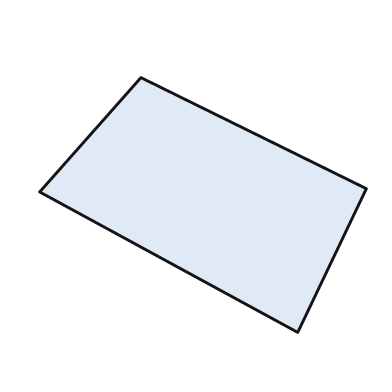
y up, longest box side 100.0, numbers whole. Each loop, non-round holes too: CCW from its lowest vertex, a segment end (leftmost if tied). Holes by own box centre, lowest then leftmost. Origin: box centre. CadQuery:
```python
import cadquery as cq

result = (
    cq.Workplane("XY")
    .moveTo(29.0, -39.0)
    .lineTo(50.0, 5.0)
    .lineTo(-19.0, 39.0)
    .lineTo(-50.0, 4.0)
    .close()
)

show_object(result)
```